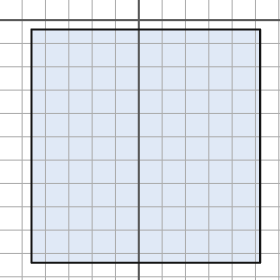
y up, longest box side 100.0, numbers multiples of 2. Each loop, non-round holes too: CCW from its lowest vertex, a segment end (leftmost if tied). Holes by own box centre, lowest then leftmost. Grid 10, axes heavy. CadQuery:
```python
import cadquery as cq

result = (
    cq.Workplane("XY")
    .moveTo(-46.0, -104.0)
    .lineTo(52.0, -104.0)
    .lineTo(52.0, -4.0)
    .lineTo(-46.0, -4.0)
    .close()
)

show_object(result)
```